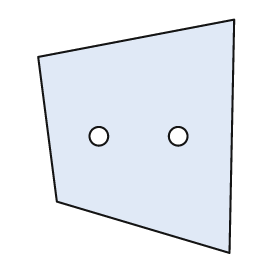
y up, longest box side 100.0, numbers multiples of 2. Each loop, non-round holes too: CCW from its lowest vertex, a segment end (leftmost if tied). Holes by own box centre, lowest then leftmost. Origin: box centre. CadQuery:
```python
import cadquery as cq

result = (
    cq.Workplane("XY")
    .moveTo(40.0, -50.0)
    .lineTo(42.0, 50.0)
    .lineTo(-42.0, 34.0)
    .lineTo(-34.0, -28.0)
    .close()
    .moveTo(-16.0, 0.0)
    .circle(4.0)
    .moveTo(18.0, 0.0)
    .circle(4.0)
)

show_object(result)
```